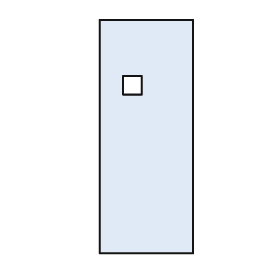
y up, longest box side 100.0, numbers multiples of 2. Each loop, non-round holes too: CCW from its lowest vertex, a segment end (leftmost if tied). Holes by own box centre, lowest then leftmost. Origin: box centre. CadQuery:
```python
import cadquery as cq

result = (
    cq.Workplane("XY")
    .moveTo(-20.0, -50.0)
    .lineTo(20.0, -50.0)
    .lineTo(20.0, 50.0)
    .lineTo(-20.0, 50.0)
    .close()
    .moveTo(-10.0, 18.0)
    .lineTo(-2.0, 18.0)
    .lineTo(-2.0, 26.0)
    .lineTo(-10.0, 26.0)
    .close()
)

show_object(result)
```